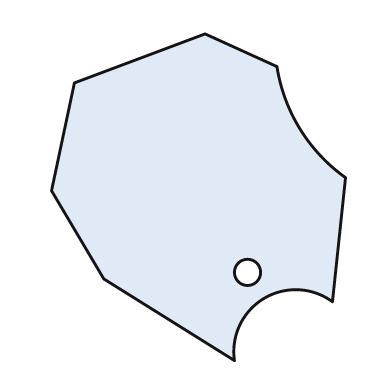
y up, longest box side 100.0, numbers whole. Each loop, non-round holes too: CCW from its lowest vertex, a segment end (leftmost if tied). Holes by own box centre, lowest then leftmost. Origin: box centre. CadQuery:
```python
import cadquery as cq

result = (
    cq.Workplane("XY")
    .moveTo(11.0, -50.0)
    .threePointArc((20.0, -31.0), (41.0, -32.0))
    .lineTo(45.0, 6.0)
    .threePointArc((31.0, 21.0), (24.0, 40.0))
    .lineTo(2.0, 50.0)
    .lineTo(-38.0, 35.0)
    .lineTo(-45.0, 2.0)
    .lineTo(-29.0, -25.0)
    .close()
    .moveTo(15.0, -23.0)
    .circle(4.0)
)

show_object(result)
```